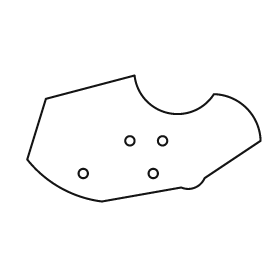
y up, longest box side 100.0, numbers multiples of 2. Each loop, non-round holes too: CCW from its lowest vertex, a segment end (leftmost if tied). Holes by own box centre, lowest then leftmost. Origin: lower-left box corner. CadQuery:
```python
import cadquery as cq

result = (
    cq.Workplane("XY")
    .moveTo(32.0, 0.0)
    .lineTo(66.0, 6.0)
    .threePointArc((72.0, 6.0), (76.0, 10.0))
    .lineTo(100.0, 26.0)
    .threePointArc((94.0, 40.0), (80.0, 46.0))
    .threePointArc((60.0, 38.0), (46.0, 54.0))
    .lineTo(8.0, 44.0)
    .lineTo(0.0, 18.0)
    .threePointArc((14.0, 6.0), (32.0, 0.0))
    .close()
    .moveTo(24.0, 12.0)
    .circle(2.0)
    .moveTo(54.0, 12.0)
    .circle(2.0)
    .moveTo(44.0, 26.0)
    .circle(2.0)
    .moveTo(58.0, 26.0)
    .circle(2.0)
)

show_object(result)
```